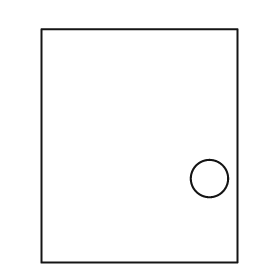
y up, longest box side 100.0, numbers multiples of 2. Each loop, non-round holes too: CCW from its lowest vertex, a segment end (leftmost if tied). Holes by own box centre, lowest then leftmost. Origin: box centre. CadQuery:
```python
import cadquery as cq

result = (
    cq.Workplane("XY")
    .moveTo(-42.0, -50.0)
    .lineTo(42.0, -50.0)
    .lineTo(42.0, 50.0)
    .lineTo(-42.0, 50.0)
    .close()
    .moveTo(30.0, -14.0)
    .circle(8.0)
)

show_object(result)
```